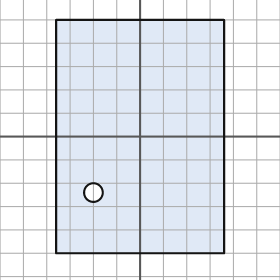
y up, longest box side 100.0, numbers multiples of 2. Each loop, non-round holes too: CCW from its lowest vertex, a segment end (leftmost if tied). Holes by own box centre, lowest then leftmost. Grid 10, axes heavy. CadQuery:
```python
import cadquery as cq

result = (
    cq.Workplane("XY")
    .moveTo(-36.0, -50.0)
    .lineTo(36.0, -50.0)
    .lineTo(36.0, 50.0)
    .lineTo(-36.0, 50.0)
    .close()
    .moveTo(-20.0, -24.0)
    .circle(4.0)
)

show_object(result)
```